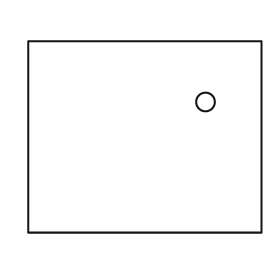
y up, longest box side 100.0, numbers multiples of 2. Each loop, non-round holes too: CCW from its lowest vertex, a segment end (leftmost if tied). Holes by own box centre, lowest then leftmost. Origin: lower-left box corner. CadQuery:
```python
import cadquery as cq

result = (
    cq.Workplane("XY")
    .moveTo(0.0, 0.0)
    .lineTo(100.0, 0.0)
    .lineTo(100.0, 82.0)
    .lineTo(0.0, 82.0)
    .close()
    .moveTo(76.0, 56.0)
    .circle(4.0)
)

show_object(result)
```